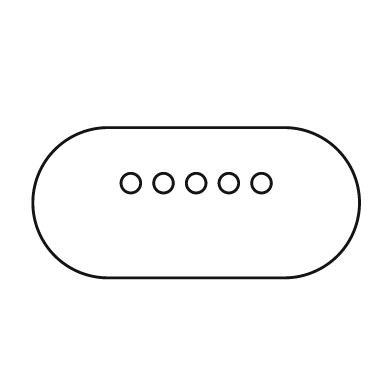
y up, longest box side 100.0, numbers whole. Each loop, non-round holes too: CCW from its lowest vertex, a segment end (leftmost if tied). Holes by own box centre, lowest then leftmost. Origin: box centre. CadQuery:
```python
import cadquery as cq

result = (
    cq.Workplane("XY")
    .moveTo(-27.0, -23.0)
    .lineTo(27.0, -23.0)
    .threePointArc((50.0, 0.0), (27.0, 23.0))
    .lineTo(-27.0, 23.0)
    .threePointArc((-50.0, 0.0), (-27.0, -23.0))
    .close()
    .moveTo(-20.0, 6.0)
    .circle(3.0)
    .moveTo(-10.0, 6.0)
    .circle(3.0)
    .moveTo(0.0, 6.0)
    .circle(3.0)
    .moveTo(10.0, 6.0)
    .circle(3.0)
    .moveTo(20.0, 6.0)
    .circle(3.0)
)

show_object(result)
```